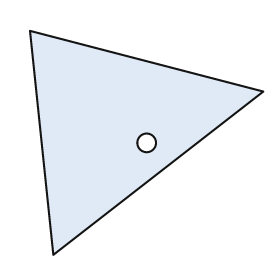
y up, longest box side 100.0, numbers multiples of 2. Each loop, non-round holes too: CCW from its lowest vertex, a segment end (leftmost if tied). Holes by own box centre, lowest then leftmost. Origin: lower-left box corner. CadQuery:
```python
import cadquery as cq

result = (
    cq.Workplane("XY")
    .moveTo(10.0, 0.0)
    .lineTo(100.0, 70.0)
    .lineTo(0.0, 96.0)
    .close()
    .moveTo(50.0, 48.0)
    .circle(4.0)
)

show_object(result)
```